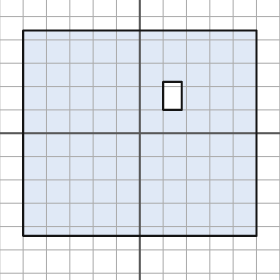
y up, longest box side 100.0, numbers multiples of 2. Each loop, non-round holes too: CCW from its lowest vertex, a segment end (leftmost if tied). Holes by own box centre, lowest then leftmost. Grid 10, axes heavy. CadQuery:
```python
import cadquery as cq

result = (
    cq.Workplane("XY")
    .moveTo(-50.0, -44.0)
    .lineTo(50.0, -44.0)
    .lineTo(50.0, 44.0)
    .lineTo(-50.0, 44.0)
    .close()
    .moveTo(10.0, 10.0)
    .lineTo(18.0, 10.0)
    .lineTo(18.0, 22.0)
    .lineTo(10.0, 22.0)
    .close()
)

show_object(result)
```